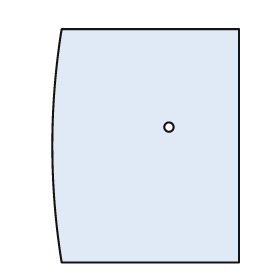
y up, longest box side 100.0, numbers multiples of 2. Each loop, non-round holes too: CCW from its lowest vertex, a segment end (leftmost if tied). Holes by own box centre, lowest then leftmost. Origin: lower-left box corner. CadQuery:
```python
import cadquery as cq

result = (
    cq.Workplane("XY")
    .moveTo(4.0, 0.0)
    .lineTo(80.0, 0.0)
    .lineTo(80.0, 100.0)
    .lineTo(4.0, 100.0)
    .threePointArc((0.0, 50.0), (4.0, 0.0))
    .close()
    .moveTo(50.0, 58.0)
    .circle(2.0)
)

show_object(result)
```